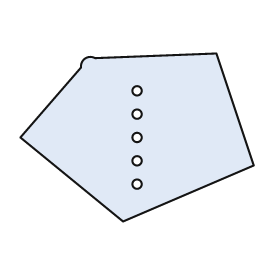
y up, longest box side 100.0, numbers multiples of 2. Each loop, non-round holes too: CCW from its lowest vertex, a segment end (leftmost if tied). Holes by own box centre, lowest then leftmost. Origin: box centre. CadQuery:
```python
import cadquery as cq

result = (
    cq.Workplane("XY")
    .moveTo(-6.0, -36.0)
    .lineTo(50.0, -12.0)
    .lineTo(34.0, 36.0)
    .lineTo(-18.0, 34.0)
    .threePointArc((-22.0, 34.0), (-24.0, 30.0))
    .lineTo(-50.0, 0.0)
    .close()
    .moveTo(0.0, -20.0)
    .circle(2.0)
    .moveTo(0.0, -10.0)
    .circle(2.0)
    .moveTo(0.0, 0.0)
    .circle(2.0)
    .moveTo(0.0, 10.0)
    .circle(2.0)
    .moveTo(0.0, 20.0)
    .circle(2.0)
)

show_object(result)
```